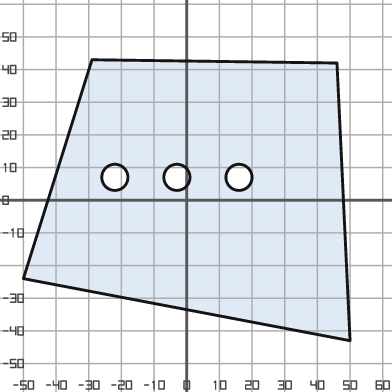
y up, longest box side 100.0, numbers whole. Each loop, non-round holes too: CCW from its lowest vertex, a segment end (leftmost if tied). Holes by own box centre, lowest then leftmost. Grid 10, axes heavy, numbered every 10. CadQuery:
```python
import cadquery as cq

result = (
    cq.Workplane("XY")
    .moveTo(50.0, -43.0)
    .lineTo(46.0, 42.0)
    .lineTo(-29.0, 43.0)
    .lineTo(-50.0, -24.0)
    .close()
    .moveTo(-22.0, 7.0)
    .circle(4.0)
    .moveTo(-3.0, 7.0)
    .circle(4.0)
    .moveTo(16.0, 7.0)
    .circle(4.0)
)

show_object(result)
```